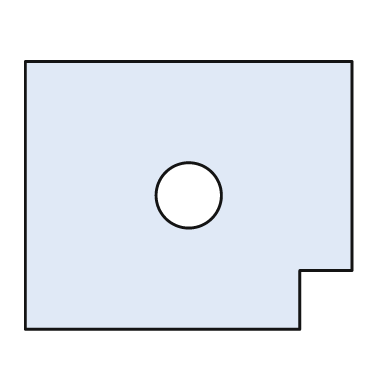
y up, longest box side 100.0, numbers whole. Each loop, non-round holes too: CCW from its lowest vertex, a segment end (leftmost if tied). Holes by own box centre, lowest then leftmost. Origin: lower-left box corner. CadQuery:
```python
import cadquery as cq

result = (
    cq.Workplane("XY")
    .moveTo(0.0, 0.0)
    .lineTo(84.0, 0.0)
    .lineTo(84.0, 18.0)
    .lineTo(100.0, 18.0)
    .lineTo(100.0, 82.0)
    .lineTo(0.0, 82.0)
    .close()
    .moveTo(50.0, 41.0)
    .circle(10.0)
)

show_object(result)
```